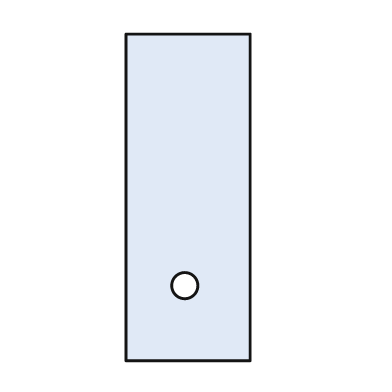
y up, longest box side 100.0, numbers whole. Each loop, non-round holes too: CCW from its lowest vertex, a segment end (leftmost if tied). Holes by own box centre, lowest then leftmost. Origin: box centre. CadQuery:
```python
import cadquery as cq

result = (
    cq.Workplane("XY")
    .moveTo(-19.0, -50.0)
    .lineTo(19.0, -50.0)
    .lineTo(19.0, 50.0)
    .lineTo(-19.0, 50.0)
    .close()
    .moveTo(-1.0, -27.0)
    .circle(4.0)
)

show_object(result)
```